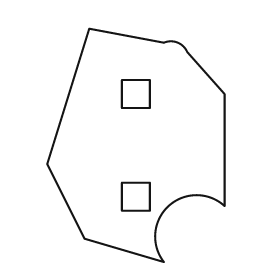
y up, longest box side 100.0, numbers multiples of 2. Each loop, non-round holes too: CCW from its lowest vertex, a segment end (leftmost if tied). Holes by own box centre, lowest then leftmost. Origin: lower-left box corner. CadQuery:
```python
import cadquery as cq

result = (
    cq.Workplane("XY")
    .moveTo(50.0, 0.0)
    .threePointArc((52.0, 24.0), (76.0, 24.0))
    .lineTo(76.0, 72.0)
    .lineTo(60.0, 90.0)
    .threePointArc((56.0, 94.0), (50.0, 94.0))
    .lineTo(18.0, 100.0)
    .lineTo(0.0, 42.0)
    .lineTo(16.0, 10.0)
    .close()
    .moveTo(32.0, 22.0)
    .lineTo(44.0, 22.0)
    .lineTo(44.0, 34.0)
    .lineTo(32.0, 34.0)
    .close()
    .moveTo(32.0, 66.0)
    .lineTo(44.0, 66.0)
    .lineTo(44.0, 78.0)
    .lineTo(32.0, 78.0)
    .close()
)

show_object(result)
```